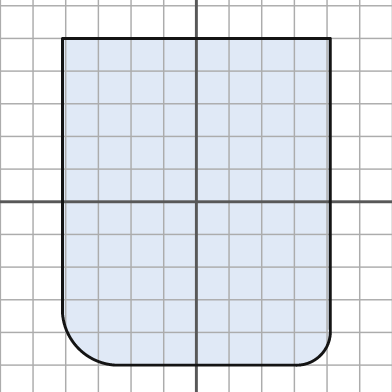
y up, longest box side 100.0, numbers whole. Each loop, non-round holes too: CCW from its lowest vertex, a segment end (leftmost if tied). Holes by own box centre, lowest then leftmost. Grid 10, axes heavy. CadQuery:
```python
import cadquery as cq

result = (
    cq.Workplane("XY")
    .moveTo(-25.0, -50.0)
    .lineTo(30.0, -50.0)
    .threePointArc((38.0, -47.0), (41.0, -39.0))
    .lineTo(41.0, 50.0)
    .lineTo(-41.0, 50.0)
    .lineTo(-41.0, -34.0)
    .threePointArc((-36.0, -45.0), (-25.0, -50.0))
    .close()
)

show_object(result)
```